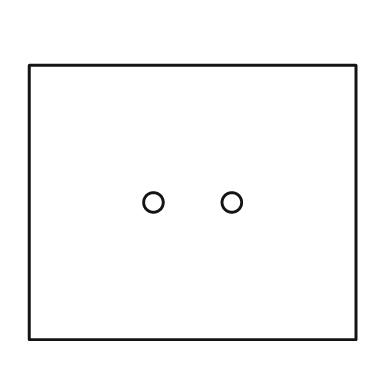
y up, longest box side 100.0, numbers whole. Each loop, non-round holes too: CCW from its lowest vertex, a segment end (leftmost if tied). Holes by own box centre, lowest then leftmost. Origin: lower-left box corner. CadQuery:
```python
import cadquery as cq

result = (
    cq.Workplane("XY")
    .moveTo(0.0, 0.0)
    .lineTo(100.0, 0.0)
    .lineTo(100.0, 84.0)
    .lineTo(0.0, 84.0)
    .close()
    .moveTo(38.0, 42.0)
    .circle(3.0)
    .moveTo(62.0, 42.0)
    .circle(3.0)
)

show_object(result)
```